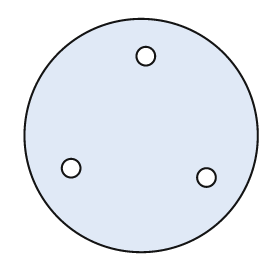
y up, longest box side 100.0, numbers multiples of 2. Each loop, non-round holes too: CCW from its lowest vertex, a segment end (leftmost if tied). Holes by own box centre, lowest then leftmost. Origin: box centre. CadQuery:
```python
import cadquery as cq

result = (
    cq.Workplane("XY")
    .moveTo(0.0, 0.0)
    .circle(50.0)
    .moveTo(28.0, -18.0)
    .circle(4.0)
    .moveTo(-30.0, -14.0)
    .circle(4.0)
    .moveTo(2.0, 34.0)
    .circle(4.0)
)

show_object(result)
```